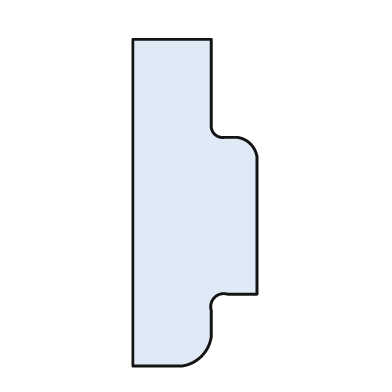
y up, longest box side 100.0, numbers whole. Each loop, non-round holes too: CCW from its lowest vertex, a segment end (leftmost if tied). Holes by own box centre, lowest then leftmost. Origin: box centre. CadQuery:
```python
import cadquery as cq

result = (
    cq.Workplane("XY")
    .moveTo(-19.0, -50.0)
    .lineTo(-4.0, -50.0)
    .threePointArc((2.0, -47.0), (5.0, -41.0))
    .lineTo(5.0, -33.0)
    .threePointArc((6.0, -29.0), (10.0, -28.0))
    .lineTo(19.0, -28.0)
    .lineTo(19.0, 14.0)
    .threePointArc((17.0, 18.0), (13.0, 20.0))
    .lineTo(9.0, 20.0)
    .threePointArc((6.0, 21.0), (5.0, 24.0))
    .lineTo(5.0, 50.0)
    .lineTo(-19.0, 50.0)
    .close()
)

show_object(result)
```